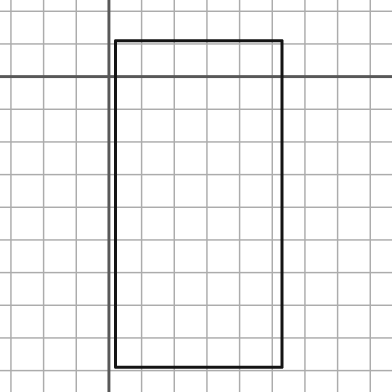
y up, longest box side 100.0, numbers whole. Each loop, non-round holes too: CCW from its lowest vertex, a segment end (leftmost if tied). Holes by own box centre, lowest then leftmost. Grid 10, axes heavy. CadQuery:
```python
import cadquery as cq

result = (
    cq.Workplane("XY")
    .moveTo(2.0, -89.0)
    .lineTo(53.0, -89.0)
    .lineTo(53.0, 11.0)
    .lineTo(2.0, 11.0)
    .close()
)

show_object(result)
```